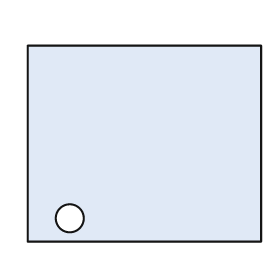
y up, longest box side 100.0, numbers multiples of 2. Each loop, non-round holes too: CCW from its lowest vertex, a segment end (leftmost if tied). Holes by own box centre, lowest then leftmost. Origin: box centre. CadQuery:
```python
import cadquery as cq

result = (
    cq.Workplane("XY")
    .moveTo(-50.0, -42.0)
    .lineTo(50.0, -42.0)
    .lineTo(50.0, 42.0)
    .lineTo(-50.0, 42.0)
    .close()
    .moveTo(-32.0, -32.0)
    .circle(6.0)
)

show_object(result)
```